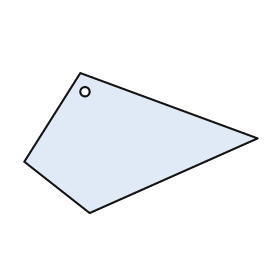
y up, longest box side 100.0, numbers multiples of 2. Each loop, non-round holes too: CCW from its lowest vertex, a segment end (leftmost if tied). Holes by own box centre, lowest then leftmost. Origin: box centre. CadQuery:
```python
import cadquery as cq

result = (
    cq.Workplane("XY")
    .moveTo(-22.0, -30.0)
    .lineTo(50.0, 2.0)
    .lineTo(-26.0, 30.0)
    .lineTo(-50.0, -8.0)
    .close()
    .moveTo(-24.0, 22.0)
    .circle(2.0)
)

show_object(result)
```